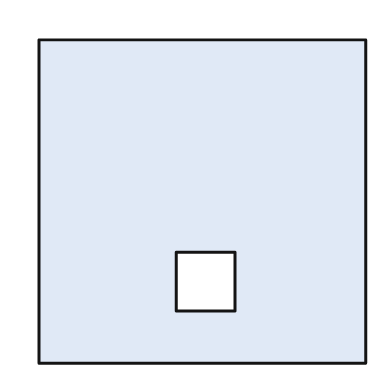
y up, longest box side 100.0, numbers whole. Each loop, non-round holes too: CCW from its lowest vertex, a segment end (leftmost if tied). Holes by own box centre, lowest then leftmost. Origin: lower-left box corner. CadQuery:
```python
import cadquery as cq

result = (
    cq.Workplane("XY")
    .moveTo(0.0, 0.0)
    .lineTo(100.0, 0.0)
    .lineTo(100.0, 99.0)
    .lineTo(0.0, 99.0)
    .close()
    .moveTo(42.0, 16.0)
    .lineTo(60.0, 16.0)
    .lineTo(60.0, 34.0)
    .lineTo(42.0, 34.0)
    .close()
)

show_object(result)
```